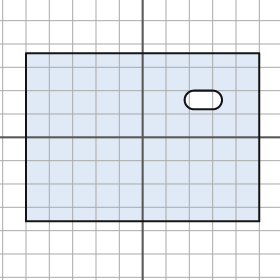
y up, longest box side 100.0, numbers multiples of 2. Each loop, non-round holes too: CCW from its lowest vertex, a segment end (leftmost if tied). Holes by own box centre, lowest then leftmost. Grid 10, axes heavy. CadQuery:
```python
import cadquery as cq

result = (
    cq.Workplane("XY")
    .moveTo(-50.0, -36.0)
    .lineTo(50.0, -36.0)
    .lineTo(50.0, 36.0)
    .lineTo(-50.0, 36.0)
    .close()
    .moveTo(22.0, 12.0)
    .lineTo(30.0, 12.0)
    .threePointArc((34.0, 16.0), (30.0, 20.0))
    .lineTo(22.0, 20.0)
    .threePointArc((18.0, 16.0), (22.0, 12.0))
    .close()
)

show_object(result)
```